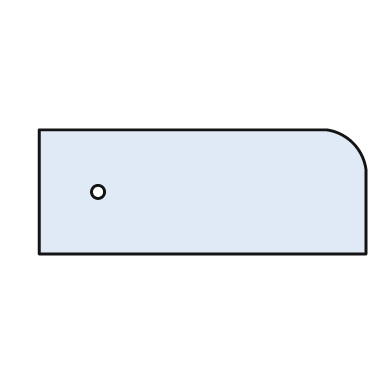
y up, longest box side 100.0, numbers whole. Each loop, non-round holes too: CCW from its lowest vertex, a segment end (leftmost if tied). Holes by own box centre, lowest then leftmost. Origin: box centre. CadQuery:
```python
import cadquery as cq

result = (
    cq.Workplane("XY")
    .moveTo(-50.0, -19.0)
    .lineTo(50.0, -19.0)
    .lineTo(50.0, 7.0)
    .threePointArc((46.0, 15.0), (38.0, 19.0))
    .lineTo(-50.0, 19.0)
    .close()
    .moveTo(-32.0, 0.0)
    .circle(2.0)
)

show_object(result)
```